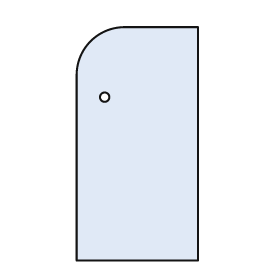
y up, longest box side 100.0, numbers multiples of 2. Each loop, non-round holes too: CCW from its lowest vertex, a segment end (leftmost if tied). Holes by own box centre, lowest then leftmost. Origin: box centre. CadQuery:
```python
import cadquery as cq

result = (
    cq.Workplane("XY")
    .moveTo(-26.0, -50.0)
    .lineTo(26.0, -50.0)
    .lineTo(26.0, 50.0)
    .lineTo(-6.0, 50.0)
    .threePointArc((-20.0, 44.0), (-26.0, 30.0))
    .close()
    .moveTo(-14.0, 20.0)
    .circle(2.0)
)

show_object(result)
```